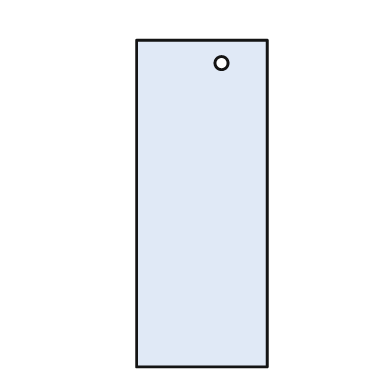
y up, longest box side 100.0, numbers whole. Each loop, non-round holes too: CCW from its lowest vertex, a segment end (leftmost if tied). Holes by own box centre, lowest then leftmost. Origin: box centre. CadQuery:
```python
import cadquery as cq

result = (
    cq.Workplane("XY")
    .moveTo(-20.0, -50.0)
    .lineTo(20.0, -50.0)
    .lineTo(20.0, 50.0)
    .lineTo(-20.0, 50.0)
    .close()
    .moveTo(6.0, 43.0)
    .circle(2.0)
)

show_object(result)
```